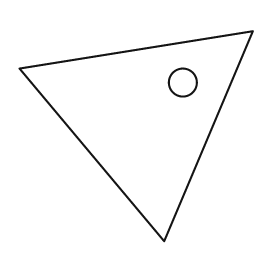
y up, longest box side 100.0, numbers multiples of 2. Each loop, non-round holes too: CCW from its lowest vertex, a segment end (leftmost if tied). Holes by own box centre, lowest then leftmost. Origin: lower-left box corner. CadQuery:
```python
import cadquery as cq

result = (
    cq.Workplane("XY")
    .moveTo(62.0, 0.0)
    .lineTo(100.0, 90.0)
    .lineTo(0.0, 74.0)
    .close()
    .moveTo(70.0, 68.0)
    .circle(6.0)
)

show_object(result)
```